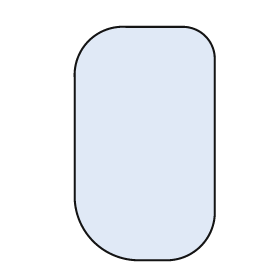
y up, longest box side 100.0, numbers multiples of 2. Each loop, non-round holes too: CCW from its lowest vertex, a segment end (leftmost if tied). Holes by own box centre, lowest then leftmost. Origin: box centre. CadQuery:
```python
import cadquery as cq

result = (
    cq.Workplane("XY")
    .moveTo(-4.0, -50.0)
    .lineTo(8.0, -50.0)
    .threePointArc((24.0, -44.0), (30.0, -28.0))
    .lineTo(30.0, 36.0)
    .threePointArc((26.0, 46.0), (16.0, 50.0))
    .lineTo(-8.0, 50.0)
    .threePointArc((-24.0, 44.0), (-30.0, 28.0))
    .lineTo(-30.0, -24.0)
    .threePointArc((-22.0, -42.0), (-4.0, -50.0))
    .close()
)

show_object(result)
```